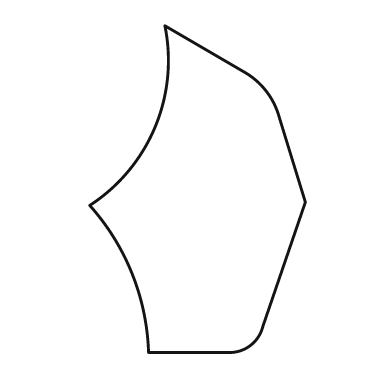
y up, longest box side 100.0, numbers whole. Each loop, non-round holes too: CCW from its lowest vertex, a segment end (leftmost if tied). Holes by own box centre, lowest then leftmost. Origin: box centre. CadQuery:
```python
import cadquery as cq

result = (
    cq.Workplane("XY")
    .moveTo(-15.0, -50.0)
    .lineTo(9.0, -50.0)
    .threePointArc((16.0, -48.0), (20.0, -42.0))
    .lineTo(33.0, -4.0)
    .lineTo(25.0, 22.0)
    .threePointArc((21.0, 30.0), (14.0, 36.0))
    .lineTo(-10.0, 50.0)
    .threePointArc((-13.0, 19.0), (-33.0, -5.0))
    .threePointArc((-20.0, -26.0), (-15.0, -50.0))
    .close()
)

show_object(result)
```